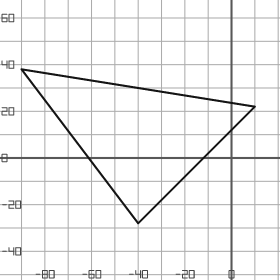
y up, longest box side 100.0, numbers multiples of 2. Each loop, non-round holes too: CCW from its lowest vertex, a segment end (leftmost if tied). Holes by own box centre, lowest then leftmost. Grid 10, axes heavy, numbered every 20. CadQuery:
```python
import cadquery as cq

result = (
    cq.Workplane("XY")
    .moveTo(-40.0, -28.0)
    .lineTo(10.0, 22.0)
    .lineTo(-90.0, 38.0)
    .close()
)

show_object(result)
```